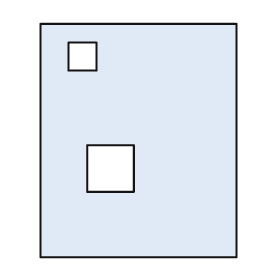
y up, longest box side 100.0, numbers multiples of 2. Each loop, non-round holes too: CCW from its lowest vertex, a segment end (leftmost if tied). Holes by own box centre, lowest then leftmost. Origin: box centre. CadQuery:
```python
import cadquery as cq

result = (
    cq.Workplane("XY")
    .moveTo(-42.0, -50.0)
    .lineTo(42.0, -50.0)
    .lineTo(42.0, 50.0)
    .lineTo(-42.0, 50.0)
    .close()
    .moveTo(-22.0, -22.0)
    .lineTo(-2.0, -22.0)
    .lineTo(-2.0, -2.0)
    .lineTo(-22.0, -2.0)
    .close()
    .moveTo(-30.0, 30.0)
    .lineTo(-18.0, 30.0)
    .lineTo(-18.0, 42.0)
    .lineTo(-30.0, 42.0)
    .close()
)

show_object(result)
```